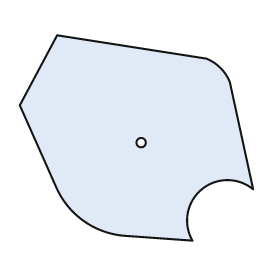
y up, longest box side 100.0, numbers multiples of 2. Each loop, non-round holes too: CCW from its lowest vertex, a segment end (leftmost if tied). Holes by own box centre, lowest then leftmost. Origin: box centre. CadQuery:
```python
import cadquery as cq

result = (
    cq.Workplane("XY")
    .moveTo(24.0, -44.0)
    .threePointArc((28.0, -22.0), (50.0, -22.0))
    .lineTo(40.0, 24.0)
    .threePointArc((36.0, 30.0), (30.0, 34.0))
    .lineTo(-34.0, 44.0)
    .lineTo(-50.0, 14.0)
    .lineTo(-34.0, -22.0)
    .threePointArc((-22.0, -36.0), (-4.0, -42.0))
    .close()
    .moveTo(2.0, -2.0)
    .circle(2.0)
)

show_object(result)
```